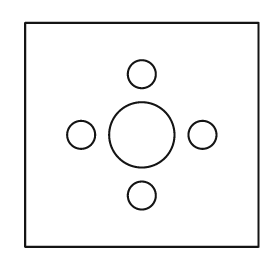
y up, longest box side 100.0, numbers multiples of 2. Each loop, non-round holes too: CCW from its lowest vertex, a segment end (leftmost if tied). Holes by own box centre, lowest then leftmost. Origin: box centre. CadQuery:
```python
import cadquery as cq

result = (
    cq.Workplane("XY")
    .moveTo(-50.0, -48.0)
    .lineTo(50.0, -48.0)
    .lineTo(50.0, 48.0)
    .lineTo(-50.0, 48.0)
    .close()
    .moveTo(0.0, -26.0)
    .circle(6.0)
    .moveTo(-26.0, 0.0)
    .circle(6.0)
    .moveTo(0.0, 0.0)
    .circle(14.0)
    .moveTo(26.0, 0.0)
    .circle(6.0)
    .moveTo(0.0, 26.0)
    .circle(6.0)
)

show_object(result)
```